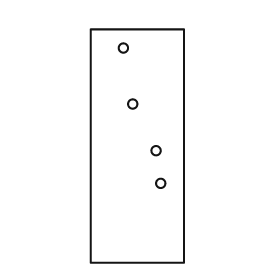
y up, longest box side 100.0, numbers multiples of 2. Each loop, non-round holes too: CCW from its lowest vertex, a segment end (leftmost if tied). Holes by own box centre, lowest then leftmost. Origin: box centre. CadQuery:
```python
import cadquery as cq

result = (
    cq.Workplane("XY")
    .moveTo(-20.0, -50.0)
    .lineTo(20.0, -50.0)
    .lineTo(20.0, 50.0)
    .lineTo(-20.0, 50.0)
    .close()
    .moveTo(10.0, -16.0)
    .circle(2.0)
    .moveTo(8.0, -2.0)
    .circle(2.0)
    .moveTo(-2.0, 18.0)
    .circle(2.0)
    .moveTo(-6.0, 42.0)
    .circle(2.0)
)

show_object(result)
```